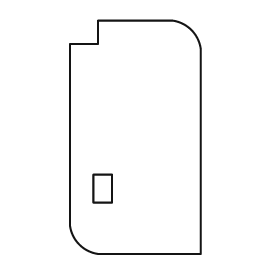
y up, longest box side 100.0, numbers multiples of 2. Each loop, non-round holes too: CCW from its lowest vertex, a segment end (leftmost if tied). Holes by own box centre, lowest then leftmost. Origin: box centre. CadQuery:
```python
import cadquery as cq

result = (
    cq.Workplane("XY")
    .moveTo(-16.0, -50.0)
    .lineTo(28.0, -50.0)
    .lineTo(28.0, 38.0)
    .threePointArc((24.0, 46.0), (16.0, 50.0))
    .lineTo(-16.0, 50.0)
    .lineTo(-16.0, 40.0)
    .lineTo(-28.0, 40.0)
    .lineTo(-28.0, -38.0)
    .threePointArc((-24.0, -46.0), (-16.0, -50.0))
    .close()
    .moveTo(-18.0, -28.0)
    .lineTo(-10.0, -28.0)
    .lineTo(-10.0, -16.0)
    .lineTo(-18.0, -16.0)
    .close()
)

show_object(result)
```